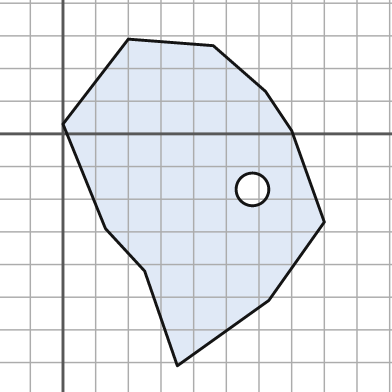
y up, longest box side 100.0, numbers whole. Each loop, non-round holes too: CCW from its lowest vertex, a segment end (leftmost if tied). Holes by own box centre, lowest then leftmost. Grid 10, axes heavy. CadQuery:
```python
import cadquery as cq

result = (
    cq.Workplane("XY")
    .moveTo(35.0, -71.0)
    .lineTo(63.0, -51.0)
    .lineTo(80.0, -27.0)
    .lineTo(70.0, 1.0)
    .lineTo(62.0, 13.0)
    .lineTo(46.0, 27.0)
    .lineTo(20.0, 29.0)
    .lineTo(0.0, 3.0)
    .lineTo(13.0, -29.0)
    .lineTo(25.0, -42.0)
    .close()
    .moveTo(58.0, -17.0)
    .circle(5.0)
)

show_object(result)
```